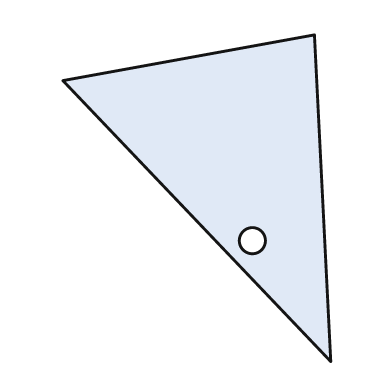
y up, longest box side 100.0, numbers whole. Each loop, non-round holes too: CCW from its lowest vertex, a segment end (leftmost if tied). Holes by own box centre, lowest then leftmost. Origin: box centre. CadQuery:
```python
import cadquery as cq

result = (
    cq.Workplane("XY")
    .moveTo(41.0, -50.0)
    .lineTo(36.0, 50.0)
    .lineTo(-41.0, 36.0)
    .close()
    .moveTo(17.0, -13.0)
    .circle(4.0)
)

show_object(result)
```